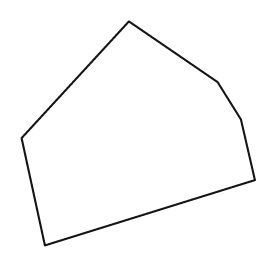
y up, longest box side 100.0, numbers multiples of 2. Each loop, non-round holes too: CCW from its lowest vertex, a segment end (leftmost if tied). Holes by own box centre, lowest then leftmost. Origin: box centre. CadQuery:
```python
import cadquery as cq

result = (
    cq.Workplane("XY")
    .moveTo(-40.0, -48.0)
    .lineTo(50.0, -20.0)
    .lineTo(44.0, 6.0)
    .lineTo(34.0, 22.0)
    .lineTo(-4.0, 48.0)
    .lineTo(-50.0, -2.0)
    .close()
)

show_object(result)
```